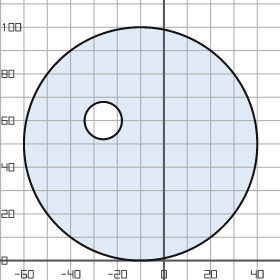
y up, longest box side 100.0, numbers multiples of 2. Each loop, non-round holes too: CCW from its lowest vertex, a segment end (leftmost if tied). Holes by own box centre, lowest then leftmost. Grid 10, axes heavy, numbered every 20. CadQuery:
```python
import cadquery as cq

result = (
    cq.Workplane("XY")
    .moveTo(-10.0, 50.0)
    .circle(50.0)
    .moveTo(-26.0, 60.0)
    .circle(8.0)
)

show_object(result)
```